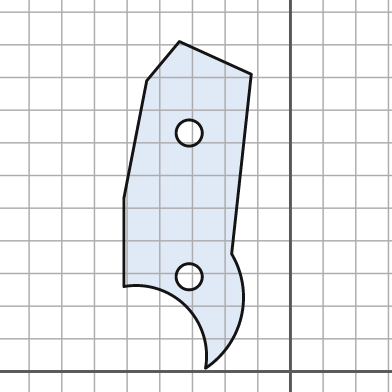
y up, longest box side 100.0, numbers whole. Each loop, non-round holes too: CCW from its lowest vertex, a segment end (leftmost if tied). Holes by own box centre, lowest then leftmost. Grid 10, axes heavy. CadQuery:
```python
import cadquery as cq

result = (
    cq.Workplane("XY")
    .moveTo(-26.0, 1.0)
    .threePointArc((-15.0, 17.0), (-18.0, 36.0))
    .lineTo(-12.0, 91.0)
    .lineTo(-34.0, 101.0)
    .lineTo(-44.0, 89.0)
    .lineTo(-51.0, 53.0)
    .lineTo(-51.0, 26.0)
    .threePointArc((-32.0, 20.0), (-26.0, 1.0))
    .close()
    .moveTo(-31.0, 29.0)
    .circle(4.0)
    .moveTo(-31.0, 73.0)
    .circle(4.0)
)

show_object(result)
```